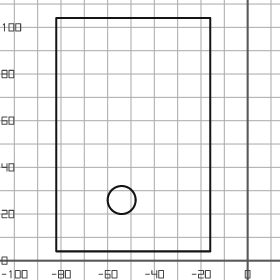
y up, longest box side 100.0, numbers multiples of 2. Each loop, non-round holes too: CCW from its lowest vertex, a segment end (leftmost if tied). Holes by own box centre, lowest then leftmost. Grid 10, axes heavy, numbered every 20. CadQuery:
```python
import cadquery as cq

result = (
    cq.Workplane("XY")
    .moveTo(-82.0, 4.0)
    .lineTo(-16.0, 4.0)
    .lineTo(-16.0, 104.0)
    .lineTo(-82.0, 104.0)
    .close()
    .moveTo(-54.0, 26.0)
    .circle(6.0)
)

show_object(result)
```